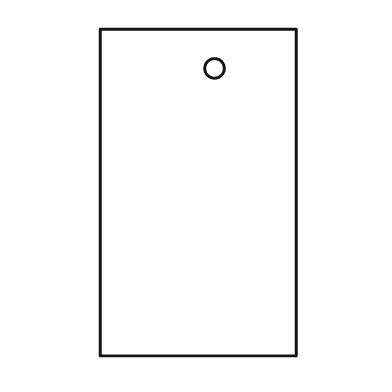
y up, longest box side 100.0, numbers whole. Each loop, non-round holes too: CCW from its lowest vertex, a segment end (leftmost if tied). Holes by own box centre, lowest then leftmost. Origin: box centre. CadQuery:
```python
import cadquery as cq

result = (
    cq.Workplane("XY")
    .moveTo(-30.0, -50.0)
    .lineTo(30.0, -50.0)
    .lineTo(30.0, 50.0)
    .lineTo(-30.0, 50.0)
    .close()
    .moveTo(5.0, 38.0)
    .circle(3.0)
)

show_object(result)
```